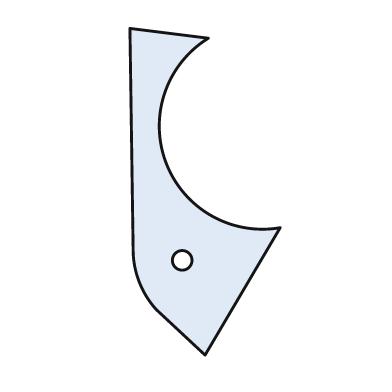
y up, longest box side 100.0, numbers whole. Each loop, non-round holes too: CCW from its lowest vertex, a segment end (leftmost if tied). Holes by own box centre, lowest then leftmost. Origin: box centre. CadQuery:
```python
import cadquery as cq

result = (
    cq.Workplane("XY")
    .moveTo(0.0, -50.0)
    .lineTo(23.0, -11.0)
    .threePointArc((-12.0, 9.0), (1.0, 47.0))
    .lineTo(-23.0, 50.0)
    .lineTo(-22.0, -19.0)
    .threePointArc((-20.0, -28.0), (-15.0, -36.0))
    .close()
    .moveTo(-7.0, -21.0)
    .circle(3.0)
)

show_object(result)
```